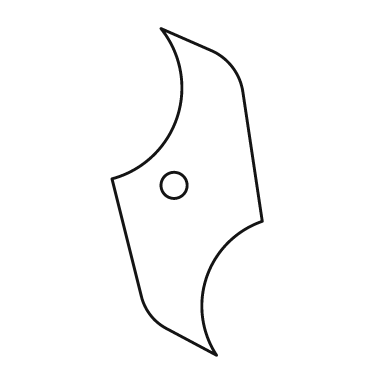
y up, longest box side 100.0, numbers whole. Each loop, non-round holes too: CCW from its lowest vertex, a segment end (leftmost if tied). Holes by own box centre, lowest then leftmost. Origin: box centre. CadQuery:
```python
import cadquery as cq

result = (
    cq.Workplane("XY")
    .moveTo(9.0, -50.0)
    .threePointArc((6.0, -26.0), (23.0, -9.0))
    .lineTo(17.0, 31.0)
    .threePointArc((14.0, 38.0), (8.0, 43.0))
    .lineTo(-8.0, 50.0)
    .threePointArc((-3.0, 23.0), (-23.0, 4.0))
    .lineTo(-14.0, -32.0)
    .threePointArc((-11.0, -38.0), (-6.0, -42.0))
    .close()
    .moveTo(-4.0, 2.0)
    .circle(4.0)
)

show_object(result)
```